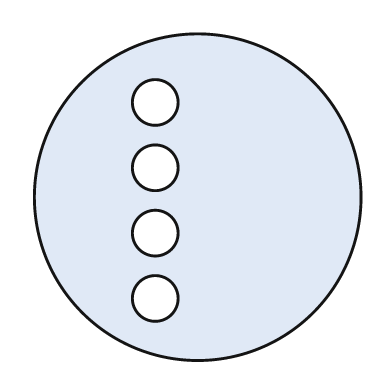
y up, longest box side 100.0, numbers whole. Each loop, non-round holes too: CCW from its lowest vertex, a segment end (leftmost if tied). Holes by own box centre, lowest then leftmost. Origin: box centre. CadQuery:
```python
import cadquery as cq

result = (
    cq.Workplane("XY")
    .moveTo(0.0, 0.0)
    .circle(50.0)
    .moveTo(-13.0, -31.0)
    .circle(7.0)
    .moveTo(-13.0, -11.0)
    .circle(7.0)
    .moveTo(-13.0, 9.0)
    .circle(7.0)
    .moveTo(-13.0, 29.0)
    .circle(7.0)
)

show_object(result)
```